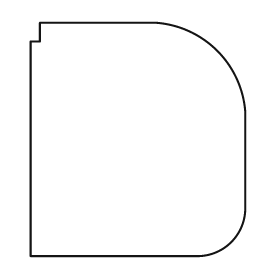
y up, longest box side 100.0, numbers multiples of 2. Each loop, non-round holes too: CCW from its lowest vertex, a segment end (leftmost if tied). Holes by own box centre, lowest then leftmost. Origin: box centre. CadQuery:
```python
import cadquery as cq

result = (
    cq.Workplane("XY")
    .moveTo(-46.0, -50.0)
    .lineTo(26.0, -50.0)
    .threePointArc((40.0, -44.0), (46.0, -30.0))
    .lineTo(46.0, 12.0)
    .threePointArc((34.0, 38.0), (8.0, 50.0))
    .lineTo(-42.0, 50.0)
    .lineTo(-42.0, 42.0)
    .lineTo(-46.0, 42.0)
    .close()
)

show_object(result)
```